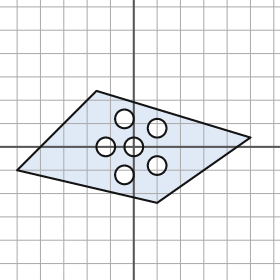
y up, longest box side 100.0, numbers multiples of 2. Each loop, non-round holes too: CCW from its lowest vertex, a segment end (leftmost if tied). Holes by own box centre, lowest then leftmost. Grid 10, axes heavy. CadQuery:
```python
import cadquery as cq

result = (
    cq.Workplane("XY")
    .moveTo(10.0, -24.0)
    .lineTo(50.0, 4.0)
    .lineTo(-16.0, 24.0)
    .lineTo(-50.0, -10.0)
    .close()
    .moveTo(-4.0, -12.0)
    .circle(4.0)
    .moveTo(10.0, -8.0)
    .circle(4.0)
    .moveTo(-12.0, 0.0)
    .circle(4.0)
    .moveTo(0.0, 0.0)
    .circle(4.0)
    .moveTo(10.0, 8.0)
    .circle(4.0)
    .moveTo(-4.0, 12.0)
    .circle(4.0)
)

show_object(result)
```